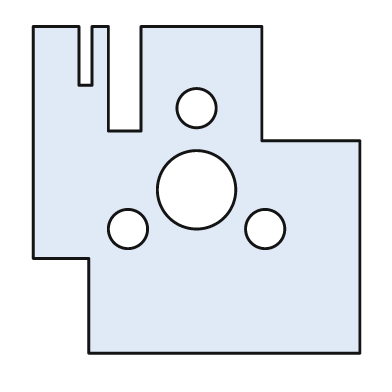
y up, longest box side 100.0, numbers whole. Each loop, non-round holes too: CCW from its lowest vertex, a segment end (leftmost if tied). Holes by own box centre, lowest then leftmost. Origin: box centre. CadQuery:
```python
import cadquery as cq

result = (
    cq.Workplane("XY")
    .moveTo(-33.0, -50.0)
    .lineTo(50.0, -50.0)
    .lineTo(50.0, 15.0)
    .lineTo(20.0, 15.0)
    .lineTo(20.0, 50.0)
    .lineTo(-17.0, 50.0)
    .lineTo(-17.0, 18.0)
    .lineTo(-27.0, 18.0)
    .lineTo(-27.0, 50.0)
    .lineTo(-32.0, 50.0)
    .lineTo(-32.0, 32.0)
    .lineTo(-36.0, 32.0)
    .lineTo(-36.0, 50.0)
    .lineTo(-50.0, 50.0)
    .lineTo(-50.0, -21.0)
    .lineTo(-33.0, -21.0)
    .close()
    .moveTo(-21.0, -12.0)
    .circle(6.0)
    .moveTo(21.0, -12.0)
    .circle(6.0)
    .moveTo(0.0, 0.0)
    .circle(12.0)
    .moveTo(0.0, 25.0)
    .circle(6.0)
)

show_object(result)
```